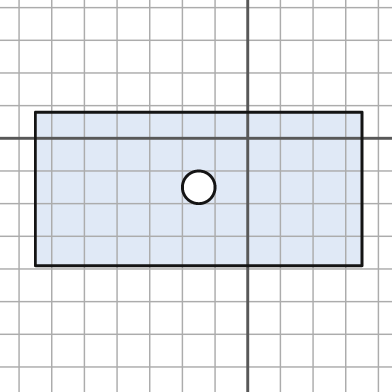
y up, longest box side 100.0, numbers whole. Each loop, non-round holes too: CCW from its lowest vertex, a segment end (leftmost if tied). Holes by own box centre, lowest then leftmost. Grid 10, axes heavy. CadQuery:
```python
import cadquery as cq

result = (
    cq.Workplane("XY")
    .moveTo(-65.0, -39.0)
    .lineTo(35.0, -39.0)
    .lineTo(35.0, 8.0)
    .lineTo(-65.0, 8.0)
    .close()
    .moveTo(-15.0, -15.0)
    .circle(5.0)
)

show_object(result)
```